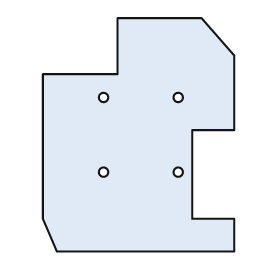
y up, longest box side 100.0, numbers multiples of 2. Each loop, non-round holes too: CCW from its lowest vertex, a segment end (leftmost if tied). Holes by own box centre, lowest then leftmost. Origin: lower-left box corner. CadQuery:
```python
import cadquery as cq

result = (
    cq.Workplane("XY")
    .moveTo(6.0, 0.0)
    .lineTo(82.0, 0.0)
    .lineTo(82.0, 14.0)
    .lineTo(64.0, 14.0)
    .lineTo(64.0, 52.0)
    .lineTo(82.0, 52.0)
    .lineTo(82.0, 84.0)
    .lineTo(68.0, 100.0)
    .lineTo(32.0, 100.0)
    .lineTo(32.0, 76.0)
    .lineTo(0.0, 76.0)
    .lineTo(0.0, 14.0)
    .close()
    .moveTo(26.0, 34.0)
    .circle(2.0)
    .moveTo(58.0, 34.0)
    .circle(2.0)
    .moveTo(26.0, 66.0)
    .circle(2.0)
    .moveTo(58.0, 66.0)
    .circle(2.0)
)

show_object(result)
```